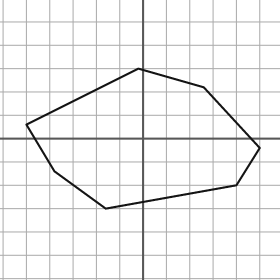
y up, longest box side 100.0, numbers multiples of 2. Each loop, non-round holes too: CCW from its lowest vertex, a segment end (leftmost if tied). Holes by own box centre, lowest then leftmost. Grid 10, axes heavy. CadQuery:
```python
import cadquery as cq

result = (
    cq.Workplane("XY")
    .moveTo(-16.0, -30.0)
    .lineTo(40.0, -20.0)
    .lineTo(50.0, -4.0)
    .lineTo(26.0, 22.0)
    .lineTo(-2.0, 30.0)
    .lineTo(-50.0, 6.0)
    .lineTo(-38.0, -14.0)
    .close()
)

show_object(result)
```